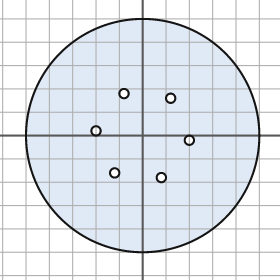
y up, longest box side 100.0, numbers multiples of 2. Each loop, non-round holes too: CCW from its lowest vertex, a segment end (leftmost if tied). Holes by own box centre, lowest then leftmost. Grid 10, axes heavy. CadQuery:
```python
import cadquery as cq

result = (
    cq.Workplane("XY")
    .moveTo(0.0, 0.0)
    .circle(50.0)
    .moveTo(8.0, -18.0)
    .circle(2.0)
    .moveTo(-12.0, -16.0)
    .circle(2.0)
    .moveTo(20.0, -2.0)
    .circle(2.0)
    .moveTo(-20.0, 2.0)
    .circle(2.0)
    .moveTo(12.0, 16.0)
    .circle(2.0)
    .moveTo(-8.0, 18.0)
    .circle(2.0)
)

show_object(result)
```